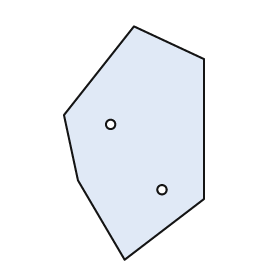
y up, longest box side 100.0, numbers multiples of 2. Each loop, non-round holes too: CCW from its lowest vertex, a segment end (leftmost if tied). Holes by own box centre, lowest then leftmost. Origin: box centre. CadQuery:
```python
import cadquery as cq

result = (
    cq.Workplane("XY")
    .moveTo(-4.0, -50.0)
    .lineTo(30.0, -24.0)
    .lineTo(30.0, 36.0)
    .lineTo(0.0, 50.0)
    .lineTo(-30.0, 12.0)
    .lineTo(-24.0, -16.0)
    .close()
    .moveTo(12.0, -20.0)
    .circle(2.0)
    .moveTo(-10.0, 8.0)
    .circle(2.0)
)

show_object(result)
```